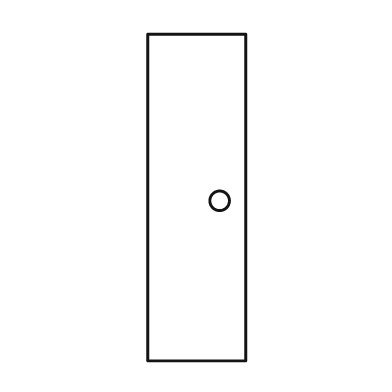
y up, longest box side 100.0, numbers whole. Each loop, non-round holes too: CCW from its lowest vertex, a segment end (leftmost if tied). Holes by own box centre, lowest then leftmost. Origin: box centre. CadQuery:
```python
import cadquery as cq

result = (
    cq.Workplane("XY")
    .moveTo(-15.0, -50.0)
    .lineTo(15.0, -50.0)
    .lineTo(15.0, 50.0)
    .lineTo(-15.0, 50.0)
    .close()
    .moveTo(7.0, -1.0)
    .circle(3.0)
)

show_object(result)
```